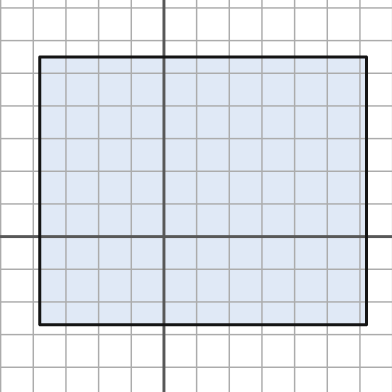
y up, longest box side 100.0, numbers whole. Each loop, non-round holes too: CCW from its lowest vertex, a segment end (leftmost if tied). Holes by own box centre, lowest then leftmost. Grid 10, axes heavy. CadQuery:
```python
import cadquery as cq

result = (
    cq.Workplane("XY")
    .moveTo(-38.0, -27.0)
    .lineTo(62.0, -27.0)
    .lineTo(62.0, 55.0)
    .lineTo(-38.0, 55.0)
    .close()
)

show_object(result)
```